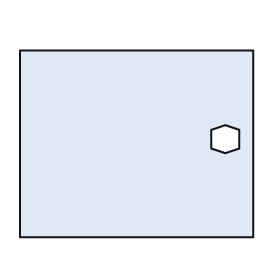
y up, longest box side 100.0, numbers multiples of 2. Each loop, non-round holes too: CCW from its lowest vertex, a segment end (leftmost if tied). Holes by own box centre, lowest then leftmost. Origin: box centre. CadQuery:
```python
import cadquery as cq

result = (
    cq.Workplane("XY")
    .moveTo(-50.0, -40.0)
    .lineTo(50.0, -40.0)
    .lineTo(50.0, 40.0)
    .lineTo(-50.0, 40.0)
    .close()
    .moveTo(38.0, -4.0)
    .lineTo(44.0, -2.0)
    .lineTo(44.0, 6.0)
    .lineTo(38.0, 8.0)
    .lineTo(32.0, 6.0)
    .lineTo(32.0, -2.0)
    .close()
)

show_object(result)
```